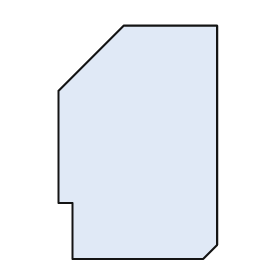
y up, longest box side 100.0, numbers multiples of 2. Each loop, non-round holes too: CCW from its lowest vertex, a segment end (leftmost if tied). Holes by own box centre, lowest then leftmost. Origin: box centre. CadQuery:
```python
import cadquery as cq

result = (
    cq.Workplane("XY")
    .moveTo(-28.0, -50.0)
    .lineTo(28.0, -50.0)
    .lineTo(34.0, -44.0)
    .lineTo(34.0, 50.0)
    .lineTo(-6.0, 50.0)
    .lineTo(-34.0, 22.0)
    .lineTo(-34.0, -26.0)
    .lineTo(-28.0, -26.0)
    .close()
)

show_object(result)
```